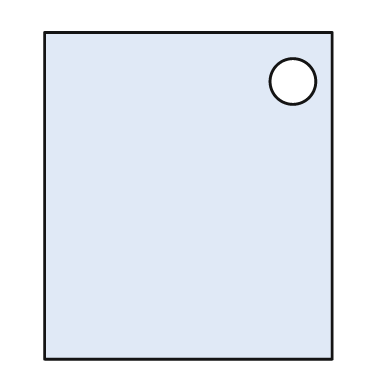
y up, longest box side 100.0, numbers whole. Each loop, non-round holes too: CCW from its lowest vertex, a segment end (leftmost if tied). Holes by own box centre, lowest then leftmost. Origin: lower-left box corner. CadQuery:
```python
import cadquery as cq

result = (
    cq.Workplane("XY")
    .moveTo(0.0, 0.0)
    .lineTo(88.0, 0.0)
    .lineTo(88.0, 100.0)
    .lineTo(0.0, 100.0)
    .close()
    .moveTo(76.0, 85.0)
    .circle(7.0)
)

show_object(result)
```